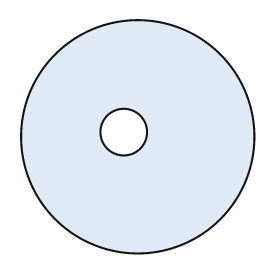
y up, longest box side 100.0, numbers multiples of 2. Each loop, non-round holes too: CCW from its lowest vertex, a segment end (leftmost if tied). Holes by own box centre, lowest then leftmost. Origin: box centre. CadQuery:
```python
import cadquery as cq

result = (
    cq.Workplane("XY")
    .moveTo(0.0, 0.0)
    .circle(50.0)
    .moveTo(-6.0, 2.0)
    .circle(10.0)
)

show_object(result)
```